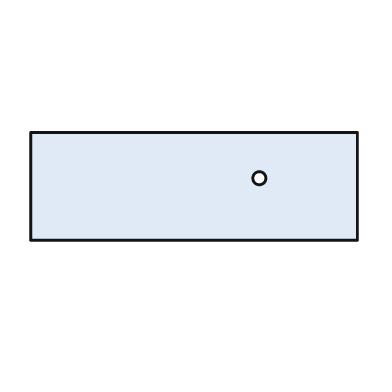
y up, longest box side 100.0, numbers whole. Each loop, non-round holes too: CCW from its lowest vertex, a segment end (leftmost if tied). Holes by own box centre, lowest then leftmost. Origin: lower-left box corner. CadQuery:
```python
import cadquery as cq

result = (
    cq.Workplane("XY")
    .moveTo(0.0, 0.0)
    .lineTo(100.0, 0.0)
    .lineTo(100.0, 33.0)
    .lineTo(0.0, 33.0)
    .close()
    .moveTo(70.0, 19.0)
    .circle(2.0)
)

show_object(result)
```